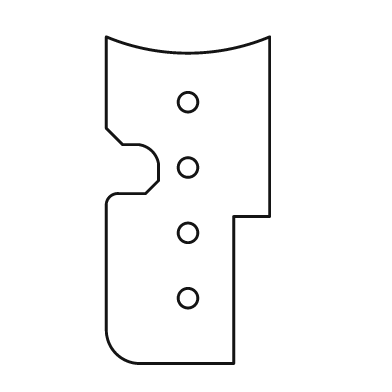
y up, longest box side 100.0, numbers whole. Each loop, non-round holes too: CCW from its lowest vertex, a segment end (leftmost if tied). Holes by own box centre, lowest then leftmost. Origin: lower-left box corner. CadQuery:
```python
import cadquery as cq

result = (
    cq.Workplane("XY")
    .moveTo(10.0, 0.0)
    .lineTo(39.0, 0.0)
    .lineTo(39.0, 45.0)
    .lineTo(50.0, 45.0)
    .lineTo(50.0, 100.0)
    .threePointArc((25.0, 95.0), (0.0, 100.0))
    .lineTo(0.0, 72.0)
    .lineTo(5.0, 67.0)
    .lineTo(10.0, 67.0)
    .threePointArc((14.0, 65.0), (16.0, 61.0))
    .lineTo(16.0, 56.0)
    .lineTo(12.0, 52.0)
    .lineTo(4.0, 52.0)
    .threePointArc((1.0, 51.0), (0.0, 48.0))
    .lineTo(0.0, 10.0)
    .threePointArc((3.0, 3.0), (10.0, 0.0))
    .close()
    .moveTo(25.0, 20.0)
    .circle(3.0)
    .moveTo(25.0, 40.0)
    .circle(3.0)
    .moveTo(25.0, 60.0)
    .circle(3.0)
    .moveTo(25.0, 80.0)
    .circle(3.0)
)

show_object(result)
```